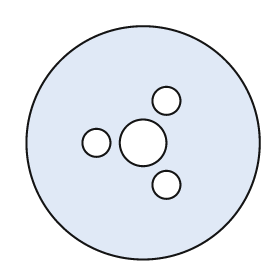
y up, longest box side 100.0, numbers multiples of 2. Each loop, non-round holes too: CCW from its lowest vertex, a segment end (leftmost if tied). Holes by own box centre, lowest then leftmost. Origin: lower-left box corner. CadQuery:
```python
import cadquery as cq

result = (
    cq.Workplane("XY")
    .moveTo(50.0, 50.0)
    .circle(50.0)
    .moveTo(60.0, 32.0)
    .circle(6.0)
    .moveTo(30.0, 50.0)
    .circle(6.0)
    .moveTo(50.0, 50.0)
    .circle(10.0)
    .moveTo(60.0, 68.0)
    .circle(6.0)
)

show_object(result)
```